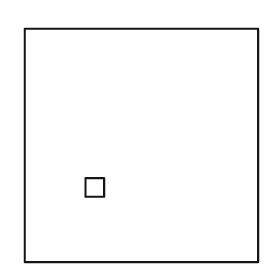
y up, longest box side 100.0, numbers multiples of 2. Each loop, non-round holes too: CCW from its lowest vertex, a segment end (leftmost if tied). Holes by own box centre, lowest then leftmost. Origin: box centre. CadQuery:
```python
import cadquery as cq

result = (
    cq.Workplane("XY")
    .moveTo(-50.0, -50.0)
    .lineTo(50.0, -50.0)
    .lineTo(50.0, 50.0)
    .lineTo(-50.0, 50.0)
    .close()
    .moveTo(-24.0, -22.0)
    .lineTo(-16.0, -22.0)
    .lineTo(-16.0, -14.0)
    .lineTo(-24.0, -14.0)
    .close()
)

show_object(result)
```